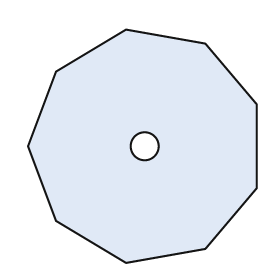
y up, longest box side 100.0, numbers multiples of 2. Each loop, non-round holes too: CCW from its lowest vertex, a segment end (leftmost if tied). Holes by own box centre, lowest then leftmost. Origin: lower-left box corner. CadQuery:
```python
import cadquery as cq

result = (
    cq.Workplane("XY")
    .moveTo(42.0, 0.0)
    .lineTo(76.0, 6.0)
    .lineTo(98.0, 32.0)
    .lineTo(98.0, 68.0)
    .lineTo(76.0, 94.0)
    .lineTo(42.0, 100.0)
    .lineTo(12.0, 82.0)
    .lineTo(0.0, 50.0)
    .lineTo(12.0, 18.0)
    .close()
    .moveTo(50.0, 50.0)
    .circle(6.0)
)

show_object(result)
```